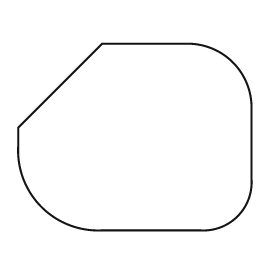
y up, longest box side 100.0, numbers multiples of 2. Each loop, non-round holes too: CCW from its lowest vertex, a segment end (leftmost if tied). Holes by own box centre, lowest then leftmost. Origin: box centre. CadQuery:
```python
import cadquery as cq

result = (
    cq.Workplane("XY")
    .moveTo(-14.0, -40.0)
    .lineTo(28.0, -40.0)
    .threePointArc((44.0, -34.0), (50.0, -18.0))
    .lineTo(50.0, 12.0)
    .threePointArc((42.0, 32.0), (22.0, 40.0))
    .lineTo(-14.0, 40.0)
    .lineTo(-50.0, 4.0)
    .lineTo(-50.0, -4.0)
    .threePointArc((-40.0, -30.0), (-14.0, -40.0))
    .close()
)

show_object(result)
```